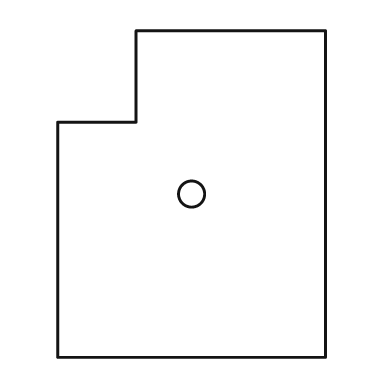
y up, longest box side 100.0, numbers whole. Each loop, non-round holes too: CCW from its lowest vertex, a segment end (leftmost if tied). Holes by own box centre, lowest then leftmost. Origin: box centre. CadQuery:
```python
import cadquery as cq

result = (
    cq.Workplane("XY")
    .moveTo(-41.0, -50.0)
    .lineTo(41.0, -50.0)
    .lineTo(41.0, 50.0)
    .lineTo(-17.0, 50.0)
    .lineTo(-17.0, 22.0)
    .lineTo(-41.0, 22.0)
    .close()
    .moveTo(0.0, 0.0)
    .circle(4.0)
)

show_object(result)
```